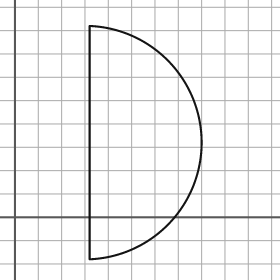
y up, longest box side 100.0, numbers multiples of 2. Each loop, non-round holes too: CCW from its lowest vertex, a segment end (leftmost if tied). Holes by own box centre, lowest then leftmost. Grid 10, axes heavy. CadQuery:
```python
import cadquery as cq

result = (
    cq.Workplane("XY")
    .moveTo(32.0, -18.0)
    .threePointArc((80.0, 32.0), (32.0, 82.0))
    .close()
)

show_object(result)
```